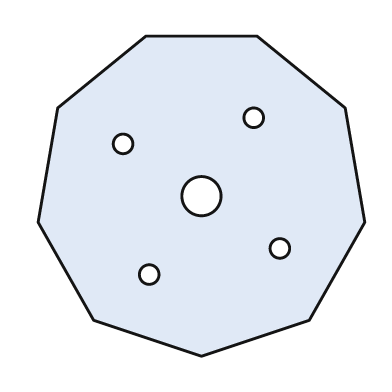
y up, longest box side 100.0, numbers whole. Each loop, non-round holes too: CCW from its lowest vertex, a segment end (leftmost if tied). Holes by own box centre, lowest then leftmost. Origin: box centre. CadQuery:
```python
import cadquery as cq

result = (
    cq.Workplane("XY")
    .moveTo(0.0, -49.0)
    .lineTo(33.0, -38.0)
    .lineTo(50.0, -8.0)
    .lineTo(44.0, 27.0)
    .lineTo(17.0, 49.0)
    .lineTo(-17.0, 49.0)
    .lineTo(-44.0, 27.0)
    .lineTo(-50.0, -8.0)
    .lineTo(-33.0, -38.0)
    .close()
    .moveTo(-16.0, -24.0)
    .circle(3.0)
    .moveTo(24.0, -16.0)
    .circle(3.0)
    .moveTo(0.0, 0.0)
    .circle(6.0)
    .moveTo(-24.0, 16.0)
    .circle(3.0)
    .moveTo(16.0, 24.0)
    .circle(3.0)
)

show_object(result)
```